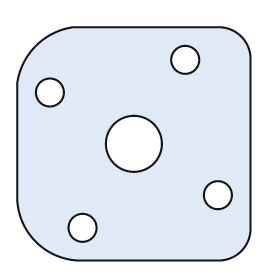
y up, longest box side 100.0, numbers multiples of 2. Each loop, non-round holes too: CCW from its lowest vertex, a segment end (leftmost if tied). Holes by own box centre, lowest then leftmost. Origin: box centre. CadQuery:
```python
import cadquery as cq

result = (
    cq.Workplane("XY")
    .moveTo(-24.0, -50.0)
    .lineTo(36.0, -50.0)
    .threePointArc((46.0, -46.0), (50.0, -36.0))
    .lineTo(50.0, 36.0)
    .threePointArc((46.0, 46.0), (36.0, 50.0))
    .lineTo(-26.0, 50.0)
    .threePointArc((-42.0, 42.0), (-50.0, 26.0))
    .lineTo(-50.0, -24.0)
    .threePointArc((-42.0, -42.0), (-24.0, -50.0))
    .close()
    .moveTo(-22.0, -36.0)
    .circle(6.0)
    .moveTo(36.0, -22.0)
    .circle(6.0)
    .moveTo(0.0, 0.0)
    .circle(12.0)
    .moveTo(-36.0, 22.0)
    .circle(6.0)
    .moveTo(22.0, 36.0)
    .circle(6.0)
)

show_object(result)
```